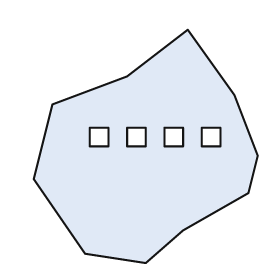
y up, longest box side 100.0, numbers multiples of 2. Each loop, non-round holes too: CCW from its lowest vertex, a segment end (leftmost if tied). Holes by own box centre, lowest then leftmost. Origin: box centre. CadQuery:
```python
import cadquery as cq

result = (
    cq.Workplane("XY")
    .moveTo(0.0, -50.0)
    .lineTo(16.0, -36.0)
    .lineTo(44.0, -20.0)
    .lineTo(48.0, -4.0)
    .lineTo(38.0, 22.0)
    .lineTo(18.0, 50.0)
    .lineTo(-8.0, 30.0)
    .lineTo(-40.0, 18.0)
    .lineTo(-48.0, -14.0)
    .lineTo(-26.0, -46.0)
    .close()
    .moveTo(-24.0, 0.0)
    .lineTo(-16.0, 0.0)
    .lineTo(-16.0, 8.0)
    .lineTo(-24.0, 8.0)
    .close()
    .moveTo(-8.0, 0.0)
    .lineTo(0.0, 0.0)
    .lineTo(0.0, 8.0)
    .lineTo(-8.0, 8.0)
    .close()
    .moveTo(8.0, 0.0)
    .lineTo(16.0, 0.0)
    .lineTo(16.0, 8.0)
    .lineTo(8.0, 8.0)
    .close()
    .moveTo(24.0, 0.0)
    .lineTo(32.0, 0.0)
    .lineTo(32.0, 8.0)
    .lineTo(24.0, 8.0)
    .close()
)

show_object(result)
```